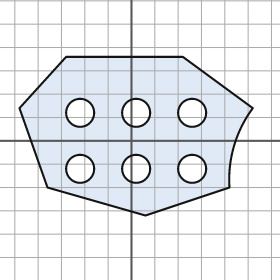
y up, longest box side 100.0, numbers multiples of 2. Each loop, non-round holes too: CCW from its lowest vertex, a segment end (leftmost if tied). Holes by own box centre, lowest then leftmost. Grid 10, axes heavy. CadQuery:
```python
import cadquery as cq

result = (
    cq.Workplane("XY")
    .moveTo(6.0, -32.0)
    .lineTo(42.0, -20.0)
    .threePointArc((44.0, -2.0), (52.0, 14.0))
    .lineTo(22.0, 36.0)
    .lineTo(-28.0, 36.0)
    .lineTo(-48.0, 14.0)
    .lineTo(-36.0, -20.0)
    .close()
    .moveTo(-22.0, -12.0)
    .circle(6.0)
    .moveTo(2.0, -12.0)
    .circle(6.0)
    .moveTo(26.0, -12.0)
    .circle(6.0)
    .moveTo(-22.0, 12.0)
    .circle(6.0)
    .moveTo(2.0, 12.0)
    .circle(6.0)
    .moveTo(26.0, 12.0)
    .circle(6.0)
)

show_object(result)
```